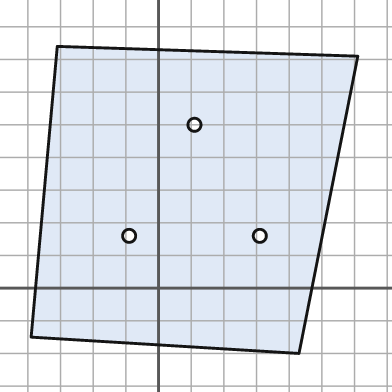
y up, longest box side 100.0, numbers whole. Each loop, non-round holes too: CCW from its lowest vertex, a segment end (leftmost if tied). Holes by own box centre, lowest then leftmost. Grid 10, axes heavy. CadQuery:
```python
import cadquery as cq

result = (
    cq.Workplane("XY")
    .moveTo(43.0, -20.0)
    .lineTo(61.0, 71.0)
    .lineTo(-31.0, 74.0)
    .lineTo(-39.0, -15.0)
    .close()
    .moveTo(-9.0, 16.0)
    .circle(2.0)
    .moveTo(31.0, 16.0)
    .circle(2.0)
    .moveTo(11.0, 50.0)
    .circle(2.0)
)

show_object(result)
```